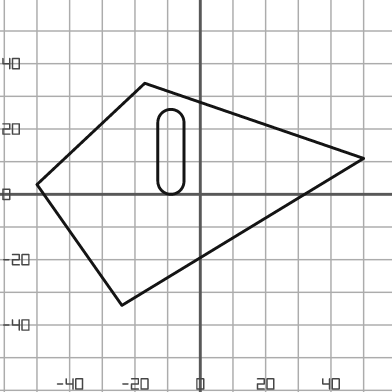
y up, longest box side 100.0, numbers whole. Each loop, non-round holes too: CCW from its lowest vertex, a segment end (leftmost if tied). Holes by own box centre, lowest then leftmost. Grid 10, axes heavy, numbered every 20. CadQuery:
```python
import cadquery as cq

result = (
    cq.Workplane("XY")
    .moveTo(-24.0, -34.0)
    .lineTo(50.0, 11.0)
    .lineTo(-17.0, 34.0)
    .lineTo(-50.0, 3.0)
    .close()
    .moveTo(-13.0, 4.0)
    .threePointArc((-9.0, 0.0), (-5.0, 4.0))
    .lineTo(-5.0, 22.0)
    .threePointArc((-9.0, 26.0), (-13.0, 22.0))
    .close()
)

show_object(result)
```